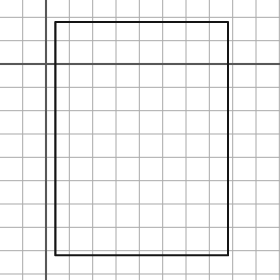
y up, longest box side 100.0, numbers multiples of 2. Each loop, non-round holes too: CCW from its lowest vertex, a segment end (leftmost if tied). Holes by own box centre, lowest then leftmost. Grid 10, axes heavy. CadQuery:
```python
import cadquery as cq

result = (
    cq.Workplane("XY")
    .moveTo(4.0, -82.0)
    .lineTo(78.0, -82.0)
    .lineTo(78.0, 18.0)
    .lineTo(4.0, 18.0)
    .close()
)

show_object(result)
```